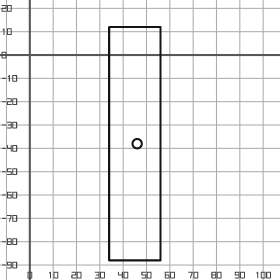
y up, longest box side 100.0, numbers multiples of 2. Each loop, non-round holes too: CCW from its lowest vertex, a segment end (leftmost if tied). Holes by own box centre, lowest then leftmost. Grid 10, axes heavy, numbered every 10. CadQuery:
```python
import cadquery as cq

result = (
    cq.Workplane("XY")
    .moveTo(34.0, -88.0)
    .lineTo(56.0, -88.0)
    .lineTo(56.0, 12.0)
    .lineTo(34.0, 12.0)
    .close()
    .moveTo(46.0, -38.0)
    .circle(2.0)
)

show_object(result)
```